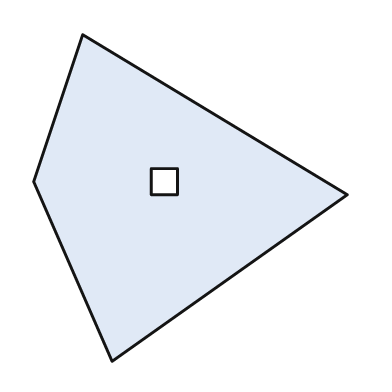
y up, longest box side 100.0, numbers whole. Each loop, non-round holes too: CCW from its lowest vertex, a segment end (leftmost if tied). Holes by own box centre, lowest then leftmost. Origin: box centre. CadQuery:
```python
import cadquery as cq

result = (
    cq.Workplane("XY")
    .moveTo(-24.0, -50.0)
    .lineTo(48.0, 1.0)
    .lineTo(-33.0, 50.0)
    .lineTo(-48.0, 5.0)
    .close()
    .moveTo(-12.0, 1.0)
    .lineTo(-4.0, 1.0)
    .lineTo(-4.0, 9.0)
    .lineTo(-12.0, 9.0)
    .close()
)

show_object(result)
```